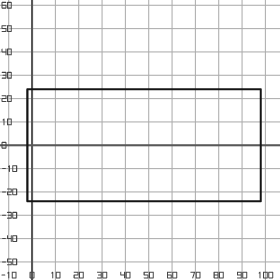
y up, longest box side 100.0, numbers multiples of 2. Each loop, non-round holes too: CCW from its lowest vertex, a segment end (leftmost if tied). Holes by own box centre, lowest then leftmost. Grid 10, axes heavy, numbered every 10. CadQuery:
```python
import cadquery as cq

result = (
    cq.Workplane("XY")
    .moveTo(-2.0, -24.0)
    .lineTo(98.0, -24.0)
    .lineTo(98.0, 24.0)
    .lineTo(-2.0, 24.0)
    .close()
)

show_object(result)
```